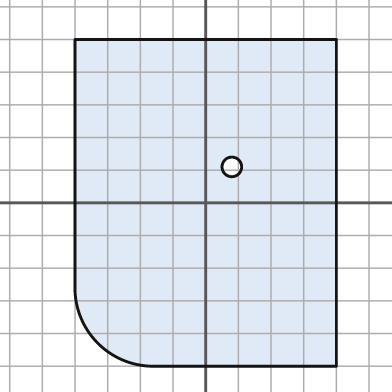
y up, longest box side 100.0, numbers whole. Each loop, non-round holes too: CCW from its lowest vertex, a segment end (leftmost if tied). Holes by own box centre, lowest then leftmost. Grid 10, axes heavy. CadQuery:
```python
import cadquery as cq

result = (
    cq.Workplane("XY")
    .moveTo(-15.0, -50.0)
    .lineTo(40.0, -50.0)
    .lineTo(40.0, 50.0)
    .lineTo(-40.0, 50.0)
    .lineTo(-40.0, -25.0)
    .threePointArc((-33.0, -43.0), (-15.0, -50.0))
    .close()
    .moveTo(8.0, 11.0)
    .circle(3.0)
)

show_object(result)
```